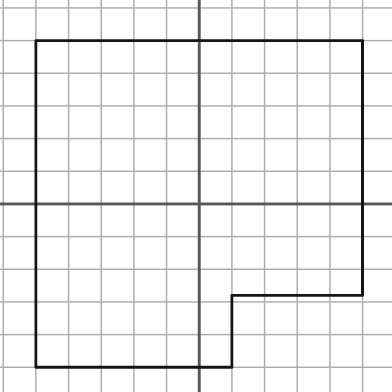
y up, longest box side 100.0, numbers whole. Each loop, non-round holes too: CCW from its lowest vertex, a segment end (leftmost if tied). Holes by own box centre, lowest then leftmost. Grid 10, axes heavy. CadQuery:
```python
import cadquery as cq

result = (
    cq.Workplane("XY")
    .moveTo(-50.0, -50.0)
    .lineTo(10.0, -50.0)
    .lineTo(10.0, -28.0)
    .lineTo(50.0, -28.0)
    .lineTo(50.0, 50.0)
    .lineTo(-50.0, 50.0)
    .close()
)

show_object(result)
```